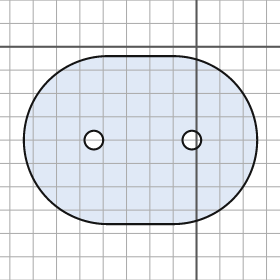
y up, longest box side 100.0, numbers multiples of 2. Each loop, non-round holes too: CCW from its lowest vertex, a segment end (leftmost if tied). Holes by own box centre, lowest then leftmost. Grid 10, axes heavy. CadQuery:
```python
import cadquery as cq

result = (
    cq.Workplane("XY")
    .moveTo(-38.0, -76.0)
    .lineTo(-10.0, -76.0)
    .threePointArc((26.0, -40.0), (-10.0, -4.0))
    .lineTo(-38.0, -4.0)
    .threePointArc((-74.0, -40.0), (-38.0, -76.0))
    .close()
    .moveTo(-44.0, -40.0)
    .circle(4.0)
    .moveTo(-2.0, -40.0)
    .circle(4.0)
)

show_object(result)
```